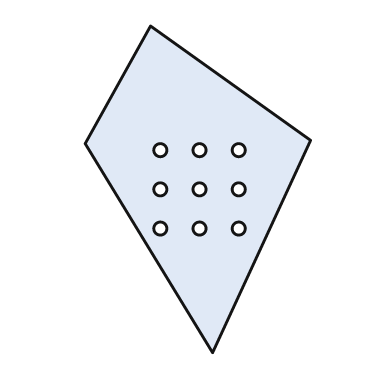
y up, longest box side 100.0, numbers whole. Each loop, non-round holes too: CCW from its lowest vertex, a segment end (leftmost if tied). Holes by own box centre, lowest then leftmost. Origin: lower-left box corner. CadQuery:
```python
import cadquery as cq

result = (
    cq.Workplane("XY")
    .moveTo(39.0, 0.0)
    .lineTo(69.0, 65.0)
    .lineTo(20.0, 100.0)
    .lineTo(0.0, 64.0)
    .close()
    .moveTo(23.0, 38.0)
    .circle(2.0)
    .moveTo(35.0, 38.0)
    .circle(2.0)
    .moveTo(47.0, 38.0)
    .circle(2.0)
    .moveTo(23.0, 50.0)
    .circle(2.0)
    .moveTo(35.0, 50.0)
    .circle(2.0)
    .moveTo(47.0, 50.0)
    .circle(2.0)
    .moveTo(23.0, 62.0)
    .circle(2.0)
    .moveTo(35.0, 62.0)
    .circle(2.0)
    .moveTo(47.0, 62.0)
    .circle(2.0)
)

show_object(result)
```